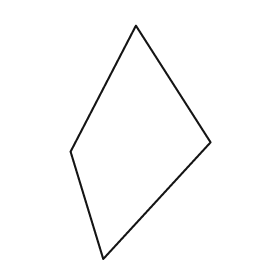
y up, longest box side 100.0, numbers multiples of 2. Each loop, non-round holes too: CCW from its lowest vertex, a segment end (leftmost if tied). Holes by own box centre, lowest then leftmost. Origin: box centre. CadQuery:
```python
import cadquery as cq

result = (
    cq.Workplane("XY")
    .moveTo(-16.0, -50.0)
    .lineTo(30.0, 0.0)
    .lineTo(-2.0, 50.0)
    .lineTo(-30.0, -4.0)
    .close()
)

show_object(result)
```